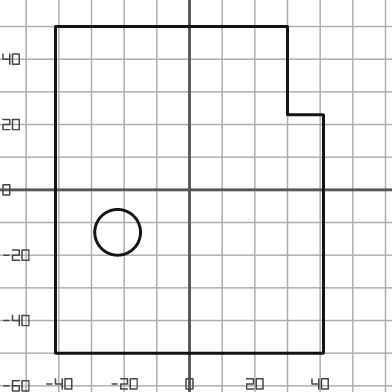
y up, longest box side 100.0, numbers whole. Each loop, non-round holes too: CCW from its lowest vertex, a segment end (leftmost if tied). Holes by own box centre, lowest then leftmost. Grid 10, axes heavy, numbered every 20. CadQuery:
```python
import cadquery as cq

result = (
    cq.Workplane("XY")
    .moveTo(-41.0, -50.0)
    .lineTo(41.0, -50.0)
    .lineTo(41.0, 23.0)
    .lineTo(30.0, 23.0)
    .lineTo(30.0, 50.0)
    .lineTo(-41.0, 50.0)
    .close()
    .moveTo(-22.0, -13.0)
    .circle(7.0)
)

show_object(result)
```